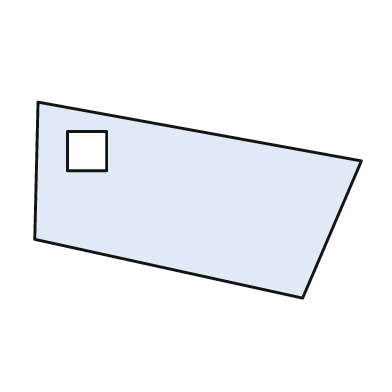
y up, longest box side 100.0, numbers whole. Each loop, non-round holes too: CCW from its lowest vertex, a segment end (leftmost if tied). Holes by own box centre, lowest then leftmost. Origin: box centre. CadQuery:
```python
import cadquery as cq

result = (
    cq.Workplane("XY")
    .moveTo(32.0, -30.0)
    .lineTo(50.0, 12.0)
    .lineTo(-49.0, 30.0)
    .lineTo(-50.0, -12.0)
    .close()
    .moveTo(-40.0, 9.0)
    .lineTo(-28.0, 9.0)
    .lineTo(-28.0, 21.0)
    .lineTo(-40.0, 21.0)
    .close()
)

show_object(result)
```